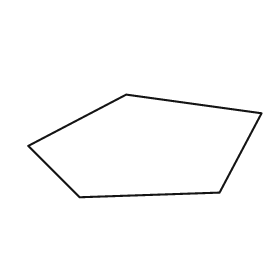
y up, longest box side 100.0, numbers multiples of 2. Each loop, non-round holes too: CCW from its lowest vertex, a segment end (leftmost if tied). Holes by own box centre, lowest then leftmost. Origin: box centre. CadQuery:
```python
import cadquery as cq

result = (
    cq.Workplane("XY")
    .moveTo(-28.0, -22.0)
    .lineTo(32.0, -20.0)
    .lineTo(50.0, 14.0)
    .lineTo(-8.0, 22.0)
    .lineTo(-50.0, 0.0)
    .close()
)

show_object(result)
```